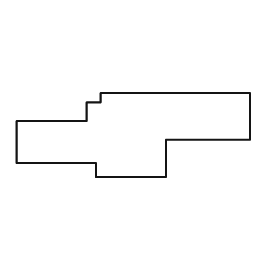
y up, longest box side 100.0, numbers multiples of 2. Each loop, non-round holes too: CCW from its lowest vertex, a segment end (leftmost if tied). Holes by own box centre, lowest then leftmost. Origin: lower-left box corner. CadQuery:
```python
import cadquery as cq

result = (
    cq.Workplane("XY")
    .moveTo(34.0, 0.0)
    .lineTo(64.0, 0.0)
    .lineTo(64.0, 16.0)
    .lineTo(100.0, 16.0)
    .lineTo(100.0, 36.0)
    .lineTo(36.0, 36.0)
    .lineTo(36.0, 32.0)
    .lineTo(30.0, 32.0)
    .lineTo(30.0, 24.0)
    .lineTo(0.0, 24.0)
    .lineTo(0.0, 6.0)
    .lineTo(34.0, 6.0)
    .close()
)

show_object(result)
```